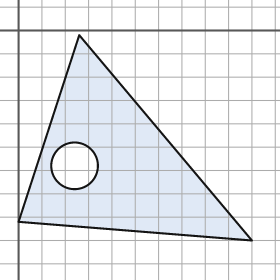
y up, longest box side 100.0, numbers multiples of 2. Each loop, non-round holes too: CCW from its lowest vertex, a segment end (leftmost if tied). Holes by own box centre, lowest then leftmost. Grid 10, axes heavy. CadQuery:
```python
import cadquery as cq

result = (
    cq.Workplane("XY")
    .moveTo(100.0, -90.0)
    .lineTo(26.0, -2.0)
    .lineTo(0.0, -82.0)
    .close()
    .moveTo(24.0, -58.0)
    .circle(10.0)
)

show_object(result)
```